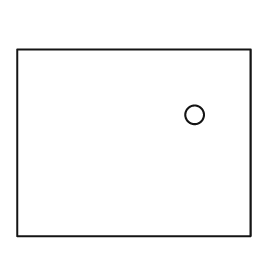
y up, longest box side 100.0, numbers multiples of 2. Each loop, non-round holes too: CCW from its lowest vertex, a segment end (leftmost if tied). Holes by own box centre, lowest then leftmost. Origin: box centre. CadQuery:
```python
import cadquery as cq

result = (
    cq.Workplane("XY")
    .moveTo(-50.0, -40.0)
    .lineTo(50.0, -40.0)
    .lineTo(50.0, 40.0)
    .lineTo(-50.0, 40.0)
    .close()
    .moveTo(26.0, 12.0)
    .circle(4.0)
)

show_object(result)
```